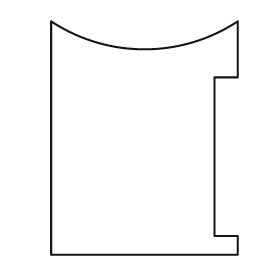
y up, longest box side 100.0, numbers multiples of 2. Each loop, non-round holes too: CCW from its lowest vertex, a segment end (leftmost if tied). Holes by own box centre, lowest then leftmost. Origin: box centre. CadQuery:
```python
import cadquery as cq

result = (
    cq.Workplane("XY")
    .moveTo(-40.0, -50.0)
    .lineTo(40.0, -50.0)
    .lineTo(40.0, -42.0)
    .lineTo(30.0, -42.0)
    .lineTo(30.0, 26.0)
    .lineTo(40.0, 26.0)
    .lineTo(40.0, 50.0)
    .threePointArc((0.0, 38.0), (-40.0, 50.0))
    .close()
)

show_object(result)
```